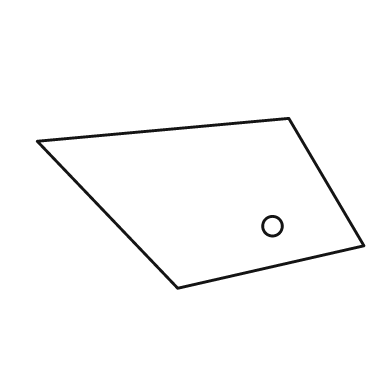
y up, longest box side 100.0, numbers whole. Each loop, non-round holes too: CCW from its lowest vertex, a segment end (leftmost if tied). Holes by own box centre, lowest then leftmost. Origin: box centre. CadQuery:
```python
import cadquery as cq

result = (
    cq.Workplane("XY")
    .moveTo(-7.0, -26.0)
    .lineTo(50.0, -13.0)
    .lineTo(27.0, 26.0)
    .lineTo(-50.0, 19.0)
    .close()
    .moveTo(22.0, -7.0)
    .circle(3.0)
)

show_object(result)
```